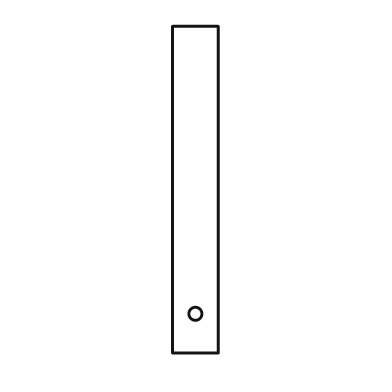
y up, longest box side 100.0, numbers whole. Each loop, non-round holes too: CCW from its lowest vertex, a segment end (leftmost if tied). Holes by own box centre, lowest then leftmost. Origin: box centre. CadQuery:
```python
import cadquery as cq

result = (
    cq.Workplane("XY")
    .moveTo(-7.0, -50.0)
    .lineTo(7.0, -50.0)
    .lineTo(7.0, 50.0)
    .lineTo(-7.0, 50.0)
    .close()
    .moveTo(0.0, -38.0)
    .circle(2.0)
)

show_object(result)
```